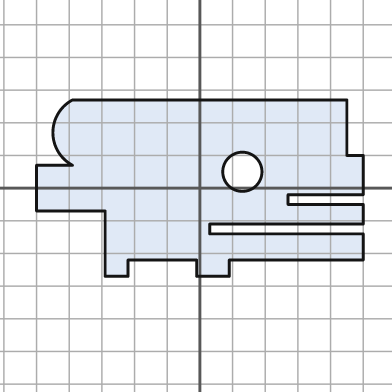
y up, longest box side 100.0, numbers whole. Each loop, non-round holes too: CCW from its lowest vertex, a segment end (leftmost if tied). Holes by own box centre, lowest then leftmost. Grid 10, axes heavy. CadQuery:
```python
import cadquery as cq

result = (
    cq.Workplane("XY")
    .moveTo(-29.0, -27.0)
    .lineTo(-22.0, -27.0)
    .lineTo(-22.0, -22.0)
    .lineTo(-1.0, -22.0)
    .lineTo(-1.0, -27.0)
    .lineTo(9.0, -27.0)
    .lineTo(9.0, -22.0)
    .lineTo(50.0, -22.0)
    .lineTo(50.0, -14.0)
    .lineTo(3.0, -14.0)
    .lineTo(3.0, -11.0)
    .lineTo(50.0, -11.0)
    .lineTo(50.0, -5.0)
    .lineTo(27.0, -5.0)
    .lineTo(27.0, -2.0)
    .lineTo(50.0, -2.0)
    .lineTo(50.0, 10.0)
    .lineTo(45.0, 10.0)
    .lineTo(45.0, 27.0)
    .lineTo(-39.0, 27.0)
    .threePointArc((-45.0, 17.0), (-39.0, 7.0))
    .lineTo(-50.0, 7.0)
    .lineTo(-50.0, -7.0)
    .lineTo(-29.0, -7.0)
    .close()
    .moveTo(13.0, 5.0)
    .circle(6.0)
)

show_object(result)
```